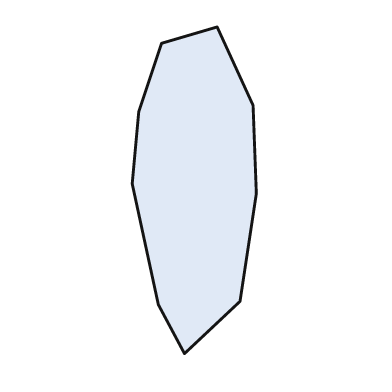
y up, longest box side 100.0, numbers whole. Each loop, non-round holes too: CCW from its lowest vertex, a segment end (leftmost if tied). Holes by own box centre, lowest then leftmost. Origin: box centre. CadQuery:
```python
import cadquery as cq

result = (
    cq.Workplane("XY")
    .moveTo(-3.0, -50.0)
    .lineTo(14.0, -34.0)
    .lineTo(19.0, -1.0)
    .lineTo(18.0, 26.0)
    .lineTo(7.0, 50.0)
    .lineTo(-10.0, 45.0)
    .lineTo(-17.0, 24.0)
    .lineTo(-19.0, 2.0)
    .lineTo(-11.0, -35.0)
    .close()
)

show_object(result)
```